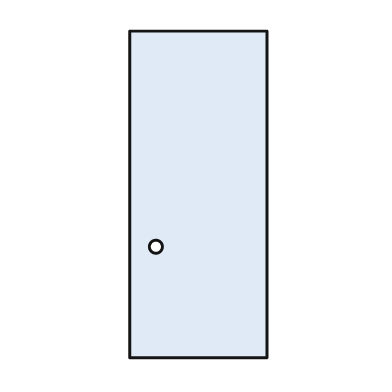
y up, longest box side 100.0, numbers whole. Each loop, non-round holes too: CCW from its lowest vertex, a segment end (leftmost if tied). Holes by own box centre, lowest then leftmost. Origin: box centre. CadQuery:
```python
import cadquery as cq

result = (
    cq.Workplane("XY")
    .moveTo(-21.0, -50.0)
    .lineTo(21.0, -50.0)
    .lineTo(21.0, 50.0)
    .lineTo(-21.0, 50.0)
    .close()
    .moveTo(-13.0, -16.0)
    .circle(2.0)
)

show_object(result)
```